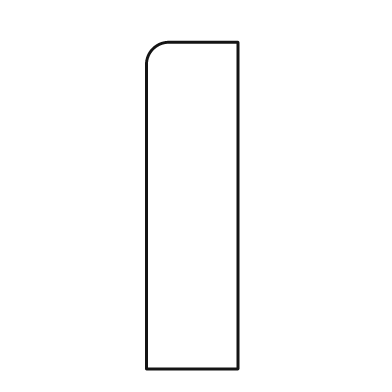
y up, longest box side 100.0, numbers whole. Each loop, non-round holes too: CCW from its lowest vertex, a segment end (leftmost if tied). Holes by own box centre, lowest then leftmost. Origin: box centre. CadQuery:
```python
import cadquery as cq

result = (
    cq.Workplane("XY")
    .moveTo(-14.0, -50.0)
    .lineTo(14.0, -50.0)
    .lineTo(14.0, 50.0)
    .lineTo(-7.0, 50.0)
    .threePointArc((-12.0, 48.0), (-14.0, 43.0))
    .close()
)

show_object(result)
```